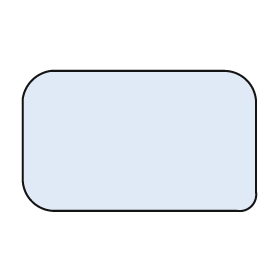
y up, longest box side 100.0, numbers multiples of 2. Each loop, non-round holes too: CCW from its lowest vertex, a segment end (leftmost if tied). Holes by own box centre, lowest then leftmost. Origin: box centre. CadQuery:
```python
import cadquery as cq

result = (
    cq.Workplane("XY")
    .moveTo(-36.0, -30.0)
    .lineTo(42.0, -30.0)
    .threePointArc((48.0, -28.0), (50.0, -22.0))
    .lineTo(50.0, 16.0)
    .threePointArc((46.0, 26.0), (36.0, 30.0))
    .lineTo(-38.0, 30.0)
    .threePointArc((-46.0, 26.0), (-50.0, 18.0))
    .lineTo(-50.0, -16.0)
    .threePointArc((-46.0, -26.0), (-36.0, -30.0))
    .close()
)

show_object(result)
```